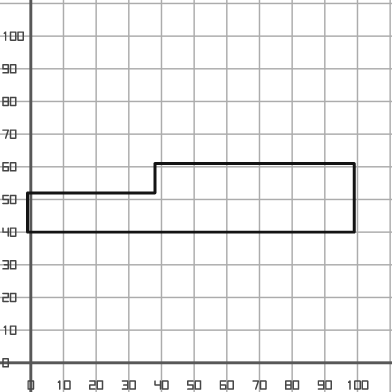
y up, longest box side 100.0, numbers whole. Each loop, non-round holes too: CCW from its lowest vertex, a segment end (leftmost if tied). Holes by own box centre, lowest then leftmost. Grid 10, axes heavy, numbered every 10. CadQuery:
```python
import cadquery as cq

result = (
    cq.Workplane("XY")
    .moveTo(-1.0, 40.0)
    .lineTo(99.0, 40.0)
    .lineTo(99.0, 61.0)
    .lineTo(38.0, 61.0)
    .lineTo(38.0, 52.0)
    .lineTo(-1.0, 52.0)
    .close()
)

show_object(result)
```